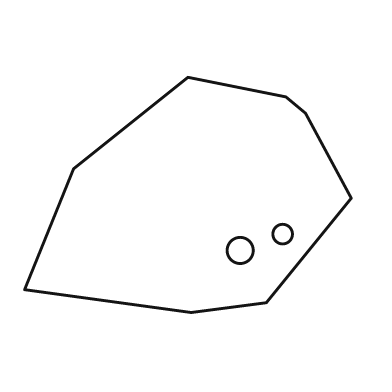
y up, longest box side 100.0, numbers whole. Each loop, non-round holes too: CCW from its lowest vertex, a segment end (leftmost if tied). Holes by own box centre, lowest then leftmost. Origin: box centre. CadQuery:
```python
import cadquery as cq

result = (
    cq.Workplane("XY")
    .moveTo(1.0, -36.0)
    .lineTo(24.0, -33.0)
    .lineTo(50.0, -1.0)
    .lineTo(36.0, 25.0)
    .lineTo(30.0, 30.0)
    .lineTo(0.0, 36.0)
    .lineTo(-35.0, 8.0)
    .lineTo(-50.0, -29.0)
    .close()
    .moveTo(16.0, -17.0)
    .circle(4.0)
    .moveTo(29.0, -12.0)
    .circle(3.0)
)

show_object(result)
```